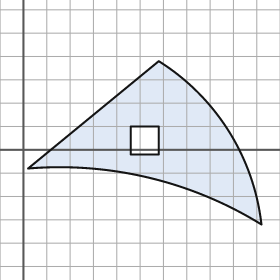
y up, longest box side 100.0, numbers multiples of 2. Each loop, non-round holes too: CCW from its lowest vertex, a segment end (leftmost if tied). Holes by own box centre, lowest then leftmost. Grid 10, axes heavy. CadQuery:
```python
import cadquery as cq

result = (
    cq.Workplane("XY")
    .moveTo(102.0, -32.0)
    .threePointArc((88.0, 8.0), (58.0, 38.0))
    .lineTo(2.0, -8.0)
    .threePointArc((54.0, -12.0), (102.0, -32.0))
    .close()
    .moveTo(46.0, -2.0)
    .lineTo(58.0, -2.0)
    .lineTo(58.0, 10.0)
    .lineTo(46.0, 10.0)
    .close()
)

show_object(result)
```